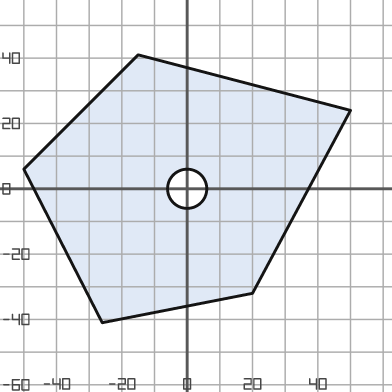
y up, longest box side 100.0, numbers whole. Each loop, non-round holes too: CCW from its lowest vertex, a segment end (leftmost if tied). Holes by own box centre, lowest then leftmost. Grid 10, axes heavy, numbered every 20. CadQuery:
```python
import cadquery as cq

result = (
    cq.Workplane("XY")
    .moveTo(-26.0, -41.0)
    .lineTo(20.0, -32.0)
    .lineTo(50.0, 24.0)
    .lineTo(-15.0, 41.0)
    .lineTo(-50.0, 6.0)
    .close()
    .moveTo(0.0, 0.0)
    .circle(6.0)
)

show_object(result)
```